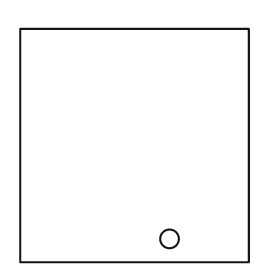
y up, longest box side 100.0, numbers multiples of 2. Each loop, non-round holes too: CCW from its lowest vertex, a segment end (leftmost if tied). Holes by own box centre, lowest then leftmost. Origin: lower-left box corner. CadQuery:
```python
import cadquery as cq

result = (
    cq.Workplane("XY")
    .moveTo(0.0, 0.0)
    .lineTo(98.0, 0.0)
    .lineTo(98.0, 100.0)
    .lineTo(0.0, 100.0)
    .close()
    .moveTo(64.0, 10.0)
    .circle(4.0)
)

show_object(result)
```